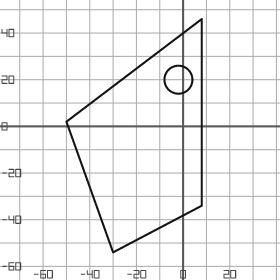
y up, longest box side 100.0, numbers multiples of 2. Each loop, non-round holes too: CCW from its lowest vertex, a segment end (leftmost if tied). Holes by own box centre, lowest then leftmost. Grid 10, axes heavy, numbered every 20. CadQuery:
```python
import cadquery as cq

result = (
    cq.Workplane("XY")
    .moveTo(-30.0, -54.0)
    .lineTo(8.0, -34.0)
    .lineTo(8.0, 46.0)
    .lineTo(-50.0, 2.0)
    .close()
    .moveTo(-2.0, 20.0)
    .circle(6.0)
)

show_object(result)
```